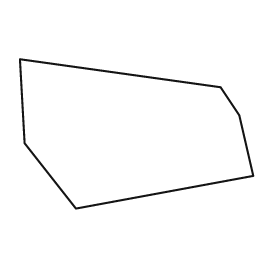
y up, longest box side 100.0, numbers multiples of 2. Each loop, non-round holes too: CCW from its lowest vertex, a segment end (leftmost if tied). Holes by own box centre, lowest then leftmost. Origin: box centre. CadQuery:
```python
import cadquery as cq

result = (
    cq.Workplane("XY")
    .moveTo(-26.0, -32.0)
    .lineTo(50.0, -18.0)
    .lineTo(44.0, 8.0)
    .lineTo(36.0, 20.0)
    .lineTo(-50.0, 32.0)
    .lineTo(-48.0, -4.0)
    .close()
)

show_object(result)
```